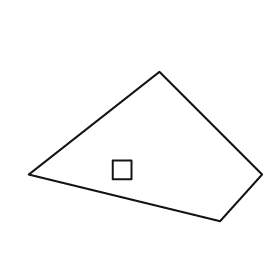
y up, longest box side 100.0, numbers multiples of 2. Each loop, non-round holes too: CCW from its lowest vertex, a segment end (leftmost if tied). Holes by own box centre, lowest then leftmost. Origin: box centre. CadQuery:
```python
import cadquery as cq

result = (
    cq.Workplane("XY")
    .moveTo(32.0, -32.0)
    .lineTo(50.0, -12.0)
    .lineTo(6.0, 32.0)
    .lineTo(-50.0, -12.0)
    .close()
    .moveTo(-14.0, -14.0)
    .lineTo(-6.0, -14.0)
    .lineTo(-6.0, -6.0)
    .lineTo(-14.0, -6.0)
    .close()
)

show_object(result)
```